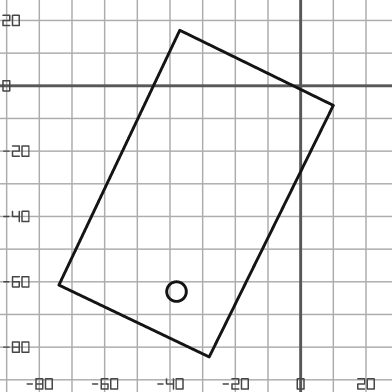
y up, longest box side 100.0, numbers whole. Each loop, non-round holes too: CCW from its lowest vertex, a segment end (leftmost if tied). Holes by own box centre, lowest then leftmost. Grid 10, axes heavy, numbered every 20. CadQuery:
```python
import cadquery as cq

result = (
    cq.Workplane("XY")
    .moveTo(-28.0, -83.0)
    .lineTo(10.0, -6.0)
    .lineTo(-37.0, 17.0)
    .lineTo(-74.0, -61.0)
    .close()
    .moveTo(-38.0, -63.0)
    .circle(3.0)
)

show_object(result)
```